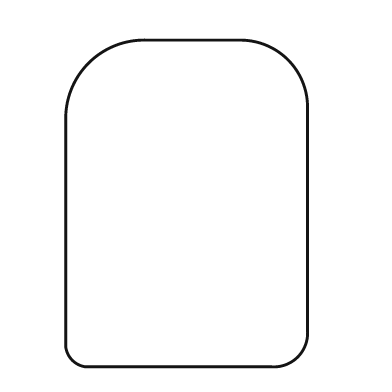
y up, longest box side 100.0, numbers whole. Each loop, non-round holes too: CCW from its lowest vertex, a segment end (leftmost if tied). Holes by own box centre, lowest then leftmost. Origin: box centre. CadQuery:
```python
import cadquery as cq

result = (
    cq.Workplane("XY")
    .moveTo(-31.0, -50.0)
    .lineTo(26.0, -50.0)
    .threePointArc((34.0, -47.0), (37.0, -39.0))
    .lineTo(37.0, 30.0)
    .threePointArc((31.0, 44.0), (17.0, 50.0))
    .lineTo(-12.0, 50.0)
    .threePointArc((-30.0, 43.0), (-37.0, 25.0))
    .lineTo(-37.0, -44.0)
    .threePointArc((-35.0, -48.0), (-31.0, -50.0))
    .close()
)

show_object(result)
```